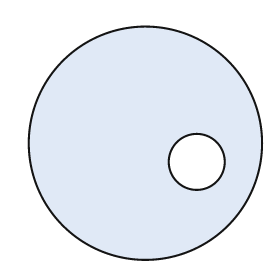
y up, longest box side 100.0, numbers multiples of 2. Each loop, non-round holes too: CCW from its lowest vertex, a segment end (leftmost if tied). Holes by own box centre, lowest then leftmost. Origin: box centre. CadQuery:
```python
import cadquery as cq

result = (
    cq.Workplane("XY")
    .moveTo(0.0, 0.0)
    .circle(50.0)
    .moveTo(22.0, -8.0)
    .circle(12.0)
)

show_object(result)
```